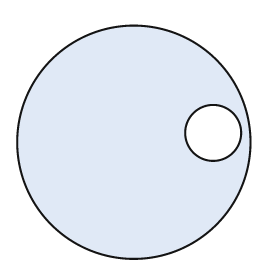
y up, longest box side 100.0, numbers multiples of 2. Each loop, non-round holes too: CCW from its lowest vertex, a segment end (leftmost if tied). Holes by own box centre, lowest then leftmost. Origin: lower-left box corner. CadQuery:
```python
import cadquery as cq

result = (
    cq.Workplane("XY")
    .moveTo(50.0, 50.0)
    .circle(50.0)
    .moveTo(84.0, 54.0)
    .circle(12.0)
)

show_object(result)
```